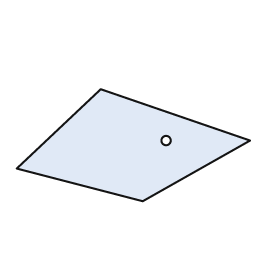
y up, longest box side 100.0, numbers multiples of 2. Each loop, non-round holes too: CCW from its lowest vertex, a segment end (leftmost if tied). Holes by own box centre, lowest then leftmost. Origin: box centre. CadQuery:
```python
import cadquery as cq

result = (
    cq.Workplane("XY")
    .moveTo(4.0, -24.0)
    .lineTo(50.0, 2.0)
    .lineTo(-14.0, 24.0)
    .lineTo(-50.0, -10.0)
    .close()
    .moveTo(14.0, 2.0)
    .circle(2.0)
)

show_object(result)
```